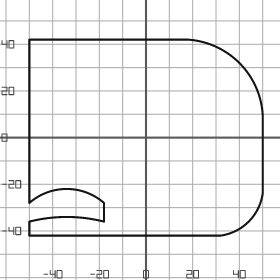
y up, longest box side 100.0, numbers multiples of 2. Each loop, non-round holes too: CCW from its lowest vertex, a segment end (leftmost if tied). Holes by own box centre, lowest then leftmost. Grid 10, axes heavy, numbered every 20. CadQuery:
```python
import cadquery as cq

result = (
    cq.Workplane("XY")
    .moveTo(-50.0, -42.0)
    .lineTo(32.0, -42.0)
    .threePointArc((44.0, -36.0), (50.0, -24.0))
    .lineTo(50.0, 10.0)
    .threePointArc((40.0, 32.0), (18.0, 42.0))
    .lineTo(-50.0, 42.0)
    .lineTo(-50.0, -28.0)
    .threePointArc((-34.0, -22.0), (-18.0, -28.0))
    .lineTo(-18.0, -36.0)
    .threePointArc((-34.0, -34.0), (-50.0, -36.0))
    .close()
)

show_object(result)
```